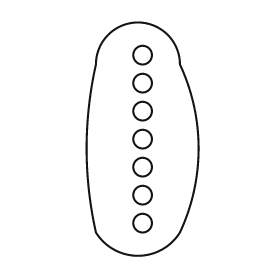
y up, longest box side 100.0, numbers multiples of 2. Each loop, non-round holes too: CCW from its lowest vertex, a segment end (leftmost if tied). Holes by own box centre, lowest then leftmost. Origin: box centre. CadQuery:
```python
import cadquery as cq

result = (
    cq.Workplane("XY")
    .moveTo(-20.0, -40.0)
    .threePointArc((-2.0, -50.0), (16.0, -40.0))
    .threePointArc((24.0, -4.0), (16.0, 32.0))
    .threePointArc((-2.0, 50.0), (-20.0, 32.0))
    .threePointArc((-24.0, -4.0), (-20.0, -40.0))
    .close()
    .moveTo(0.0, -36.0)
    .circle(4.0)
    .moveTo(0.0, -24.0)
    .circle(4.0)
    .moveTo(0.0, -12.0)
    .circle(4.0)
    .moveTo(0.0, 0.0)
    .circle(4.0)
    .moveTo(0.0, 12.0)
    .circle(4.0)
    .moveTo(0.0, 24.0)
    .circle(4.0)
    .moveTo(0.0, 36.0)
    .circle(4.0)
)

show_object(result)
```